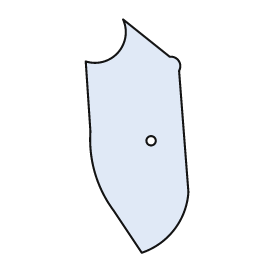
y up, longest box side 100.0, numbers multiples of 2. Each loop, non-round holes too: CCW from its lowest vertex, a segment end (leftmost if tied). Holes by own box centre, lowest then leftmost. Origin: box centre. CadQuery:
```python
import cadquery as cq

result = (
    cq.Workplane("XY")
    .moveTo(2.0, -50.0)
    .threePointArc((16.0, -40.0), (22.0, -24.0))
    .lineTo(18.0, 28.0)
    .threePointArc((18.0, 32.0), (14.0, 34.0))
    .lineTo(-6.0, 50.0)
    .threePointArc((-8.0, 36.0), (-22.0, 32.0))
    .lineTo(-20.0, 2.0)
    .threePointArc((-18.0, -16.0), (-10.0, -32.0))
    .close()
    .moveTo(6.0, -2.0)
    .circle(2.0)
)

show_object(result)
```